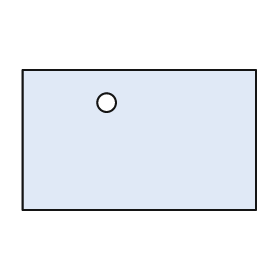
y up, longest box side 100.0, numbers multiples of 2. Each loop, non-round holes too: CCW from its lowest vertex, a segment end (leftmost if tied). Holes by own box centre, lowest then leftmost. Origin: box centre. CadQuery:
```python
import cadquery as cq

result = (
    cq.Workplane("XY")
    .moveTo(-50.0, -30.0)
    .lineTo(50.0, -30.0)
    .lineTo(50.0, 30.0)
    .lineTo(-50.0, 30.0)
    .close()
    .moveTo(-14.0, 16.0)
    .circle(4.0)
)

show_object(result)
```